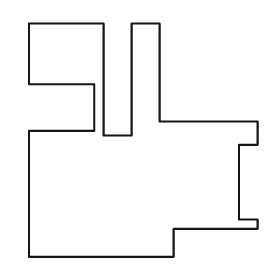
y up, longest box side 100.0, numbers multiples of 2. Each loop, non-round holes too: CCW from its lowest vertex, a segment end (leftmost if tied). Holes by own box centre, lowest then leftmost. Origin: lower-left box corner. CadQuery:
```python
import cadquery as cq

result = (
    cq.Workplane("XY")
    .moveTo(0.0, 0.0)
    .lineTo(62.0, 0.0)
    .lineTo(62.0, 12.0)
    .lineTo(98.0, 12.0)
    .lineTo(98.0, 16.0)
    .lineTo(90.0, 16.0)
    .lineTo(90.0, 48.0)
    .lineTo(98.0, 48.0)
    .lineTo(98.0, 58.0)
    .lineTo(56.0, 58.0)
    .lineTo(56.0, 100.0)
    .lineTo(44.0, 100.0)
    .lineTo(44.0, 52.0)
    .lineTo(32.0, 52.0)
    .lineTo(32.0, 100.0)
    .lineTo(0.0, 100.0)
    .lineTo(0.0, 74.0)
    .lineTo(28.0, 74.0)
    .lineTo(28.0, 54.0)
    .lineTo(0.0, 54.0)
    .close()
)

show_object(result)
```